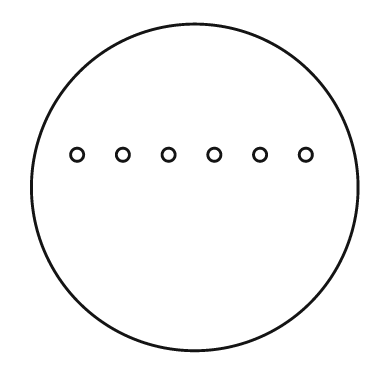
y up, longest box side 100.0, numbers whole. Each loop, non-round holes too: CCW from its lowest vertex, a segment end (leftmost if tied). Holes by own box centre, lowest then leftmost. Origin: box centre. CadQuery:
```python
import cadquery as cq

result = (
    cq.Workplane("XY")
    .moveTo(0.0, 0.0)
    .circle(50.0)
    .moveTo(-36.0, 10.0)
    .circle(2.0)
    .moveTo(-22.0, 10.0)
    .circle(2.0)
    .moveTo(-8.0, 10.0)
    .circle(2.0)
    .moveTo(6.0, 10.0)
    .circle(2.0)
    .moveTo(20.0, 10.0)
    .circle(2.0)
    .moveTo(34.0, 10.0)
    .circle(2.0)
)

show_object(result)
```